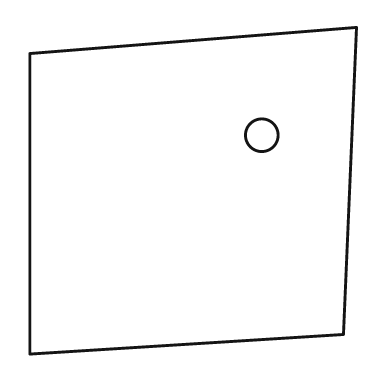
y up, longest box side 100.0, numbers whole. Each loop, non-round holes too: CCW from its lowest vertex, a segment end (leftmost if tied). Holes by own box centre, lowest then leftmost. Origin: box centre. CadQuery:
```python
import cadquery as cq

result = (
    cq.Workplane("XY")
    .moveTo(-50.0, -50.0)
    .lineTo(46.0, -44.0)
    .lineTo(50.0, 50.0)
    .lineTo(-50.0, 42.0)
    .close()
    .moveTo(21.0, 17.0)
    .circle(5.0)
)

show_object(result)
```